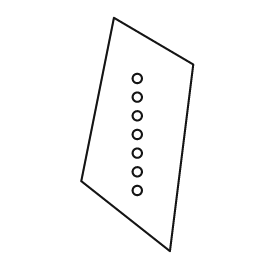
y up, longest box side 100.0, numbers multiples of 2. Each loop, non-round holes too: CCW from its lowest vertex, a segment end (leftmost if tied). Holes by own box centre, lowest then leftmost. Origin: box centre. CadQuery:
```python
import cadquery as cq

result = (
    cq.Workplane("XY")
    .moveTo(14.0, -50.0)
    .lineTo(24.0, 30.0)
    .lineTo(-10.0, 50.0)
    .lineTo(-24.0, -20.0)
    .close()
    .moveTo(0.0, -24.0)
    .circle(2.0)
    .moveTo(0.0, -16.0)
    .circle(2.0)
    .moveTo(0.0, -8.0)
    .circle(2.0)
    .moveTo(0.0, 0.0)
    .circle(2.0)
    .moveTo(0.0, 8.0)
    .circle(2.0)
    .moveTo(0.0, 16.0)
    .circle(2.0)
    .moveTo(0.0, 24.0)
    .circle(2.0)
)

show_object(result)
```